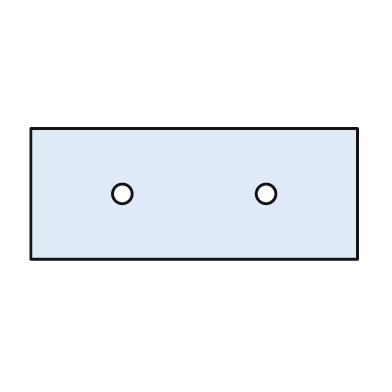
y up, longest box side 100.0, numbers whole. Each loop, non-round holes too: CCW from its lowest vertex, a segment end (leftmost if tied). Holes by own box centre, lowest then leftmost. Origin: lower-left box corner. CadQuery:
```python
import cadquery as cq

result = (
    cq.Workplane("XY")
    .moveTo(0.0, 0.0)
    .lineTo(100.0, 0.0)
    .lineTo(100.0, 40.0)
    .lineTo(0.0, 40.0)
    .close()
    .moveTo(28.0, 20.0)
    .circle(3.0)
    .moveTo(72.0, 20.0)
    .circle(3.0)
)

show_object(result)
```